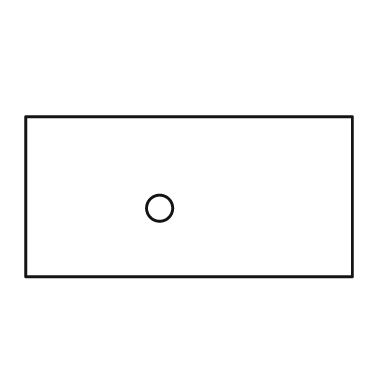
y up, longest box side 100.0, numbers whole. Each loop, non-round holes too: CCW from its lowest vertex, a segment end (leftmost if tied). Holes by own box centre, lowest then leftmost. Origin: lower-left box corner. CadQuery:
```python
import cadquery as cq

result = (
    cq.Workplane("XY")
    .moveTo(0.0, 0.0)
    .lineTo(100.0, 0.0)
    .lineTo(100.0, 49.0)
    .lineTo(0.0, 49.0)
    .close()
    .moveTo(41.0, 21.0)
    .circle(4.0)
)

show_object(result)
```